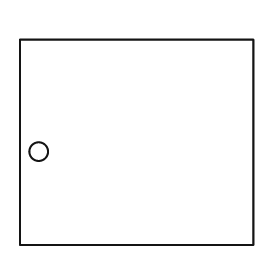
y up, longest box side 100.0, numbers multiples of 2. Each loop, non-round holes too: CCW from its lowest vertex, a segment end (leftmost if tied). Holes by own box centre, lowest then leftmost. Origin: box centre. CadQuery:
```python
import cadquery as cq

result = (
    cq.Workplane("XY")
    .moveTo(-50.0, -44.0)
    .lineTo(50.0, -44.0)
    .lineTo(50.0, 44.0)
    .lineTo(-50.0, 44.0)
    .close()
    .moveTo(-42.0, -4.0)
    .circle(4.0)
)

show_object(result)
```